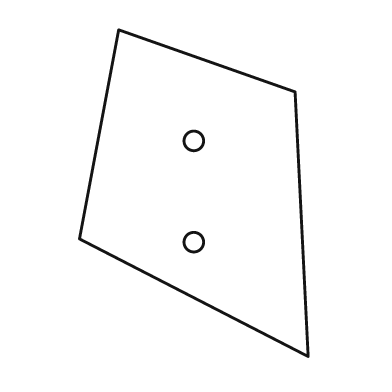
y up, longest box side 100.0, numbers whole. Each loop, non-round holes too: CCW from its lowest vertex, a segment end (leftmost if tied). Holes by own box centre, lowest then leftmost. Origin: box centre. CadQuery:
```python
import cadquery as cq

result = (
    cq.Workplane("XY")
    .moveTo(35.0, -50.0)
    .lineTo(31.0, 31.0)
    .lineTo(-23.0, 50.0)
    .lineTo(-35.0, -14.0)
    .close()
    .moveTo(0.0, -15.0)
    .circle(3.0)
    .moveTo(0.0, 16.0)
    .circle(3.0)
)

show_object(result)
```